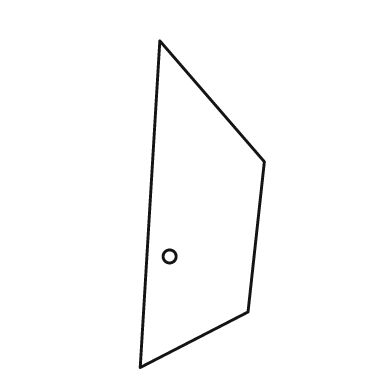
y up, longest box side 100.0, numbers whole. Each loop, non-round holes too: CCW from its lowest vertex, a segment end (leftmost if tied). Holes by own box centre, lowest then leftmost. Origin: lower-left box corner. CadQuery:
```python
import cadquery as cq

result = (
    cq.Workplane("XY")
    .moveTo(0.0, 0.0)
    .lineTo(33.0, 17.0)
    .lineTo(38.0, 63.0)
    .lineTo(6.0, 100.0)
    .close()
    .moveTo(9.0, 34.0)
    .circle(2.0)
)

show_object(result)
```